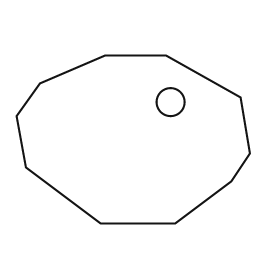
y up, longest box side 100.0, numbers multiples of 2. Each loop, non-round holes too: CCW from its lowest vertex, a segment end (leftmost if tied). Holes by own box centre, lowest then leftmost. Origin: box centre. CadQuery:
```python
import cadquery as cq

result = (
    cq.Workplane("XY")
    .moveTo(-14.0, -36.0)
    .lineTo(18.0, -36.0)
    .lineTo(42.0, -18.0)
    .lineTo(50.0, -6.0)
    .lineTo(46.0, 18.0)
    .lineTo(14.0, 36.0)
    .lineTo(-12.0, 36.0)
    .lineTo(-40.0, 24.0)
    .lineTo(-50.0, 10.0)
    .lineTo(-46.0, -12.0)
    .close()
    .moveTo(16.0, 16.0)
    .circle(6.0)
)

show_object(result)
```